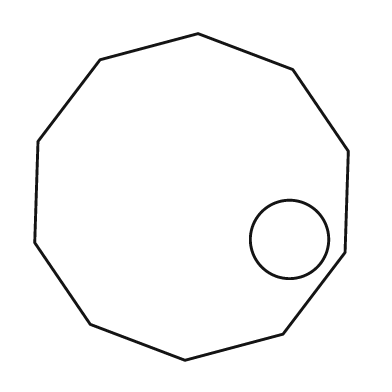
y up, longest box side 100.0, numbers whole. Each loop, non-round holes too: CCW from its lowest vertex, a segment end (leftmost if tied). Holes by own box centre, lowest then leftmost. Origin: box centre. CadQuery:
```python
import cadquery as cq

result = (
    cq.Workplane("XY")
    .moveTo(-2.0, -50.0)
    .lineTo(28.0, -42.0)
    .lineTo(47.0, -17.0)
    .lineTo(48.0, 14.0)
    .lineTo(31.0, 39.0)
    .lineTo(2.0, 50.0)
    .lineTo(-28.0, 42.0)
    .lineTo(-47.0, 17.0)
    .lineTo(-48.0, -14.0)
    .lineTo(-31.0, -39.0)
    .close()
    .moveTo(30.0, -13.0)
    .circle(12.0)
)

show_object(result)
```